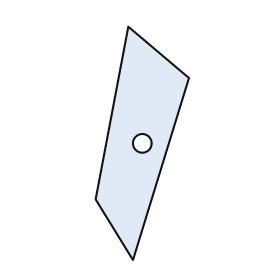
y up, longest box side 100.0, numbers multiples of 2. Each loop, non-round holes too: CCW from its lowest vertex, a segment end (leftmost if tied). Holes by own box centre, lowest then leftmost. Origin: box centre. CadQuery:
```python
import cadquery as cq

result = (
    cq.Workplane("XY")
    .moveTo(-4.0, -50.0)
    .lineTo(20.0, 28.0)
    .lineTo(-6.0, 50.0)
    .lineTo(-20.0, -24.0)
    .close()
    .moveTo(0.0, 0.0)
    .circle(4.0)
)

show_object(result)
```